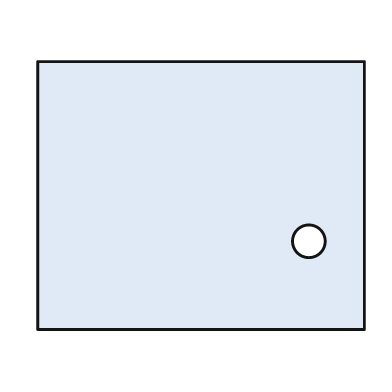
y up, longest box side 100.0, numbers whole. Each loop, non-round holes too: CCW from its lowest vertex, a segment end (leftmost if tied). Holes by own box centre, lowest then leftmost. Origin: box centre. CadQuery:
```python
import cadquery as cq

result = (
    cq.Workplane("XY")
    .moveTo(-50.0, -41.0)
    .lineTo(50.0, -41.0)
    .lineTo(50.0, 41.0)
    .lineTo(-50.0, 41.0)
    .close()
    .moveTo(33.0, -14.0)
    .circle(5.0)
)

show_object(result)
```